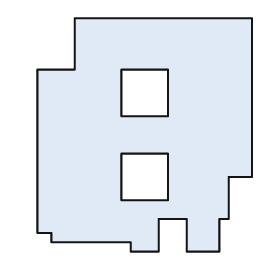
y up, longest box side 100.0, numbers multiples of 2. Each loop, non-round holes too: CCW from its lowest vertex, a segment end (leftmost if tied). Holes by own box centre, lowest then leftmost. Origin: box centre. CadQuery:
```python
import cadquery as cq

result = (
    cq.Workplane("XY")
    .moveTo(-6.0, -50.0)
    .lineTo(6.0, -50.0)
    .lineTo(6.0, -36.0)
    .lineTo(18.0, -36.0)
    .lineTo(18.0, -50.0)
    .lineTo(32.0, -50.0)
    .lineTo(32.0, -36.0)
    .lineTo(36.0, -36.0)
    .lineTo(36.0, -18.0)
    .lineTo(46.0, -18.0)
    .lineTo(46.0, 50.0)
    .lineTo(-30.0, 50.0)
    .lineTo(-30.0, 28.0)
    .lineTo(-46.0, 28.0)
    .lineTo(-46.0, -42.0)
    .lineTo(-40.0, -42.0)
    .lineTo(-40.0, -46.0)
    .lineTo(-6.0, -46.0)
    .close()
    .moveTo(-10.0, -28.0)
    .lineTo(10.0, -28.0)
    .lineTo(10.0, -8.0)
    .lineTo(-10.0, -8.0)
    .close()
    .moveTo(-10.0, 8.0)
    .lineTo(10.0, 8.0)
    .lineTo(10.0, 28.0)
    .lineTo(-10.0, 28.0)
    .close()
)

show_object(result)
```